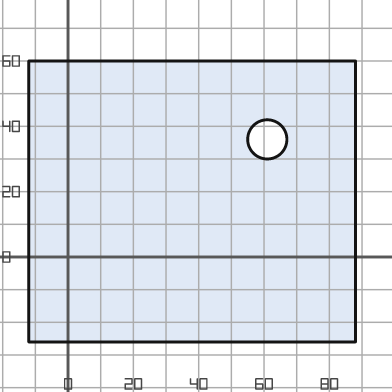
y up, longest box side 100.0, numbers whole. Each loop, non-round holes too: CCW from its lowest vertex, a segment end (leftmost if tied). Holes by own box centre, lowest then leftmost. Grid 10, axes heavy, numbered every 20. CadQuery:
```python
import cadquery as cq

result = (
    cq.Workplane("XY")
    .moveTo(-12.0, -26.0)
    .lineTo(88.0, -26.0)
    .lineTo(88.0, 60.0)
    .lineTo(-12.0, 60.0)
    .close()
    .moveTo(61.0, 36.0)
    .circle(6.0)
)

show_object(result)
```